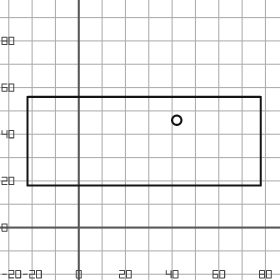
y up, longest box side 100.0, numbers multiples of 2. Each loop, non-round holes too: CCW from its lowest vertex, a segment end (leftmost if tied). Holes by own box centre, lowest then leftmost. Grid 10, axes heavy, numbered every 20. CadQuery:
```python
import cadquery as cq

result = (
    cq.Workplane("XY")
    .moveTo(-22.0, 18.0)
    .lineTo(78.0, 18.0)
    .lineTo(78.0, 56.0)
    .lineTo(-22.0, 56.0)
    .close()
    .moveTo(42.0, 46.0)
    .circle(2.0)
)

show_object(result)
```